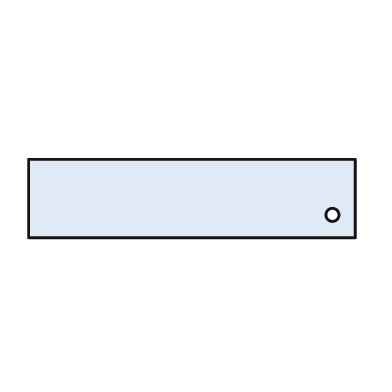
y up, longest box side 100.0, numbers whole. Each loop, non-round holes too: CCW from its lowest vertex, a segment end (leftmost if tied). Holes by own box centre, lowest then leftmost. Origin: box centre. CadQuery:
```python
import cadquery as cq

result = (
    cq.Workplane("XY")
    .moveTo(-50.0, -12.0)
    .lineTo(50.0, -12.0)
    .lineTo(50.0, 12.0)
    .lineTo(-50.0, 12.0)
    .close()
    .moveTo(43.0, -5.0)
    .circle(2.0)
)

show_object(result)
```